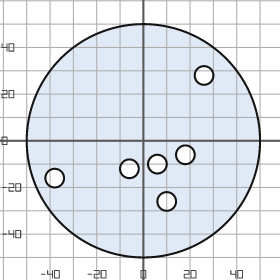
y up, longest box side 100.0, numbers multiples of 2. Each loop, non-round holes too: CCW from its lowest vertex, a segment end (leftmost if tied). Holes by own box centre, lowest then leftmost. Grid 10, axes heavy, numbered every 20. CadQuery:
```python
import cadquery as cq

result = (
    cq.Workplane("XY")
    .moveTo(0.0, 0.0)
    .circle(50.0)
    .moveTo(10.0, -26.0)
    .circle(4.0)
    .moveTo(-38.0, -16.0)
    .circle(4.0)
    .moveTo(-6.0, -12.0)
    .circle(4.0)
    .moveTo(6.0, -10.0)
    .circle(4.0)
    .moveTo(18.0, -6.0)
    .circle(4.0)
    .moveTo(26.0, 28.0)
    .circle(4.0)
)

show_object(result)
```